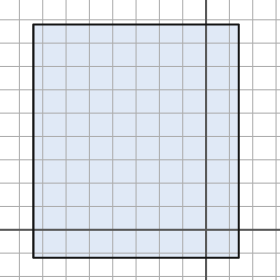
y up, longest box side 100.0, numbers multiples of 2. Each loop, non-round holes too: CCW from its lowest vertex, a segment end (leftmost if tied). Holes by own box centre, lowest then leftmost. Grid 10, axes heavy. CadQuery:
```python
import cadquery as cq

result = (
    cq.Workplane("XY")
    .moveTo(-74.0, -12.0)
    .lineTo(14.0, -12.0)
    .lineTo(14.0, 88.0)
    .lineTo(-74.0, 88.0)
    .close()
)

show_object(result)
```